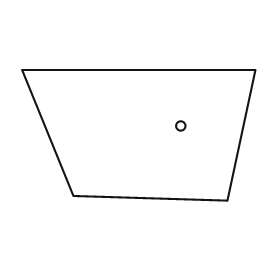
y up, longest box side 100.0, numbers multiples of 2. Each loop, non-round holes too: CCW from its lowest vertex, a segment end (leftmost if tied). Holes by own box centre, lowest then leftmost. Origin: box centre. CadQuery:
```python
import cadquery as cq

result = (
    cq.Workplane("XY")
    .moveTo(38.0, -28.0)
    .lineTo(50.0, 28.0)
    .lineTo(-50.0, 28.0)
    .lineTo(-28.0, -26.0)
    .close()
    .moveTo(18.0, 4.0)
    .circle(2.0)
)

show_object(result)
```